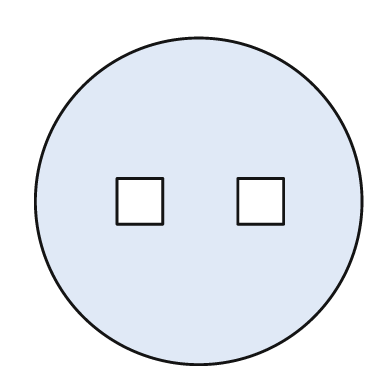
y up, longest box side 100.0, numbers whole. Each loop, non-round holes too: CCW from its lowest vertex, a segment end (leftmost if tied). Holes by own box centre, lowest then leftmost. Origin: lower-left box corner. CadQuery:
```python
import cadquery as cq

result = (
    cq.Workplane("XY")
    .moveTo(50.0, 50.0)
    .circle(50.0)
    .moveTo(25.0, 43.0)
    .lineTo(39.0, 43.0)
    .lineTo(39.0, 57.0)
    .lineTo(25.0, 57.0)
    .close()
    .moveTo(62.0, 43.0)
    .lineTo(76.0, 43.0)
    .lineTo(76.0, 57.0)
    .lineTo(62.0, 57.0)
    .close()
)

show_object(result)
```